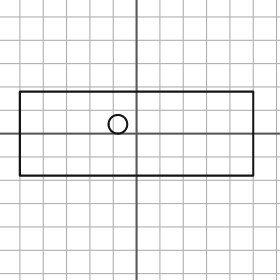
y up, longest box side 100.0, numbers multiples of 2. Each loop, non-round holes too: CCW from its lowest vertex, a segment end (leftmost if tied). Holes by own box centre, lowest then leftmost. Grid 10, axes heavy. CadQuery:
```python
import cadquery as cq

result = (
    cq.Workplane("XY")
    .moveTo(-50.0, -18.0)
    .lineTo(50.0, -18.0)
    .lineTo(50.0, 18.0)
    .lineTo(-50.0, 18.0)
    .close()
    .moveTo(-8.0, 4.0)
    .circle(4.0)
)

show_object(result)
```